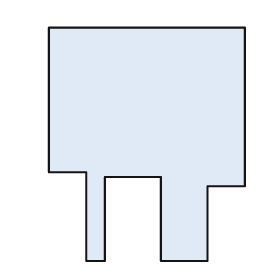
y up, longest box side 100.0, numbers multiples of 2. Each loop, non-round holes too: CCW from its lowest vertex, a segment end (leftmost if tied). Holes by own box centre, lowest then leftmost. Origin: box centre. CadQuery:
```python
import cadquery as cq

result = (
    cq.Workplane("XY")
    .moveTo(-26.0, -50.0)
    .lineTo(-18.0, -50.0)
    .lineTo(-18.0, -14.0)
    .lineTo(6.0, -14.0)
    .lineTo(6.0, -50.0)
    .lineTo(26.0, -50.0)
    .lineTo(26.0, -18.0)
    .lineTo(42.0, -18.0)
    .lineTo(42.0, 50.0)
    .lineTo(-42.0, 50.0)
    .lineTo(-42.0, -12.0)
    .lineTo(-26.0, -12.0)
    .close()
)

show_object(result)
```